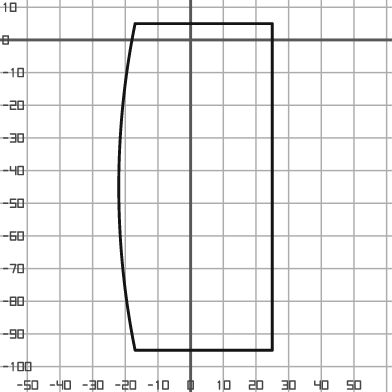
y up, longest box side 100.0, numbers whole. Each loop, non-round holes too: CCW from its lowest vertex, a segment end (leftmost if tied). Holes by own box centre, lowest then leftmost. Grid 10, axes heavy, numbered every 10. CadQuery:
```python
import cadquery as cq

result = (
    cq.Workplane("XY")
    .moveTo(-17.0, -95.0)
    .lineTo(25.0, -95.0)
    .lineTo(25.0, 5.0)
    .lineTo(-17.0, 5.0)
    .threePointArc((-22.0, -45.0), (-17.0, -95.0))
    .close()
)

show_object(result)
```